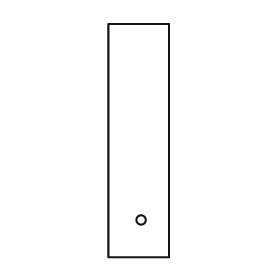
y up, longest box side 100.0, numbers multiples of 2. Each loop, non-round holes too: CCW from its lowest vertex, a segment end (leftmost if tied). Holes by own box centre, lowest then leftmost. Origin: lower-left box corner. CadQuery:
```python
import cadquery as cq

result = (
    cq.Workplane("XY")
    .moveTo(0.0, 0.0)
    .lineTo(26.0, 0.0)
    .lineTo(26.0, 100.0)
    .lineTo(0.0, 100.0)
    .close()
    .moveTo(14.0, 16.0)
    .circle(2.0)
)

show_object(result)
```